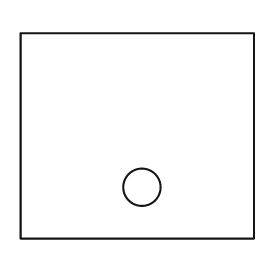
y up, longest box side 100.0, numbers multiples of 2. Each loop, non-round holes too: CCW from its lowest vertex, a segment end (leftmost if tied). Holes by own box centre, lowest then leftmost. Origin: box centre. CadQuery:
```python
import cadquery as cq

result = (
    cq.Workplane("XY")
    .moveTo(-50.0, -44.0)
    .lineTo(50.0, -44.0)
    .lineTo(50.0, 44.0)
    .lineTo(-50.0, 44.0)
    .close()
    .moveTo(2.0, -22.0)
    .circle(8.0)
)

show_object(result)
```